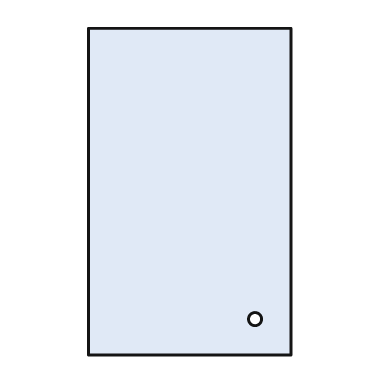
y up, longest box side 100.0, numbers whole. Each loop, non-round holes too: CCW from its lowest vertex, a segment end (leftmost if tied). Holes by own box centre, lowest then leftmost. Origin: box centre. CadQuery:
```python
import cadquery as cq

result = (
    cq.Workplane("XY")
    .moveTo(-31.0, -50.0)
    .lineTo(31.0, -50.0)
    .lineTo(31.0, 50.0)
    .lineTo(-31.0, 50.0)
    .close()
    .moveTo(20.0, -39.0)
    .circle(2.0)
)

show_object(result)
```